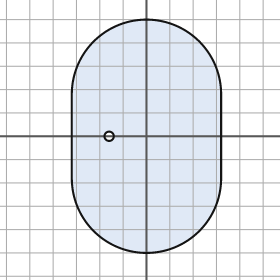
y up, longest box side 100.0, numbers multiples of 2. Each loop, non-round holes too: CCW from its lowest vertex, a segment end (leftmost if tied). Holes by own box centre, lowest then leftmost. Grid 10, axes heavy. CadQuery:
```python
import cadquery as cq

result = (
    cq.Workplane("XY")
    .moveTo(-32.0, -18.0)
    .threePointArc((0.0, -50.0), (32.0, -18.0))
    .lineTo(32.0, 18.0)
    .threePointArc((0.0, 50.0), (-32.0, 18.0))
    .close()
    .moveTo(-16.0, 0.0)
    .circle(2.0)
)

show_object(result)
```